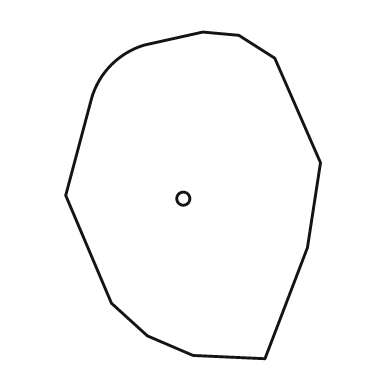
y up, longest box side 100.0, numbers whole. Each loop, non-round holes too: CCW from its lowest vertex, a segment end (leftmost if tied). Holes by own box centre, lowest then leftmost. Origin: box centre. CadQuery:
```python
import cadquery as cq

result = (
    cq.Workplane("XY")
    .moveTo(22.0, -50.0)
    .lineTo(35.0, -16.0)
    .lineTo(39.0, 10.0)
    .lineTo(25.0, 42.0)
    .lineTo(14.0, 49.0)
    .lineTo(3.0, 50.0)
    .lineTo(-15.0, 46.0)
    .threePointArc((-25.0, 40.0), (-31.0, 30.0))
    .lineTo(-39.0, 0.0)
    .lineTo(-25.0, -33.0)
    .lineTo(-14.0, -43.0)
    .lineTo(0.0, -49.0)
    .close()
    .moveTo(-3.0, -1.0)
    .circle(2.0)
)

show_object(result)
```